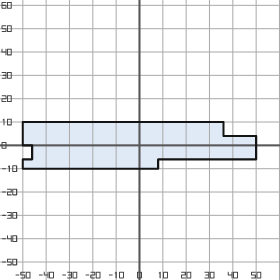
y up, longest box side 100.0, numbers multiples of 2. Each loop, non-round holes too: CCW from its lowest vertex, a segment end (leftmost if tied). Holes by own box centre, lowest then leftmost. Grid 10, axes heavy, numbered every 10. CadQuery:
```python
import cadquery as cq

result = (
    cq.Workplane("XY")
    .moveTo(-50.0, -10.0)
    .lineTo(8.0, -10.0)
    .lineTo(8.0, -6.0)
    .lineTo(50.0, -6.0)
    .lineTo(50.0, 4.0)
    .lineTo(36.0, 4.0)
    .lineTo(36.0, 10.0)
    .lineTo(-50.0, 10.0)
    .lineTo(-50.0, 0.0)
    .lineTo(-46.0, 0.0)
    .lineTo(-46.0, -6.0)
    .lineTo(-50.0, -6.0)
    .close()
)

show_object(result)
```